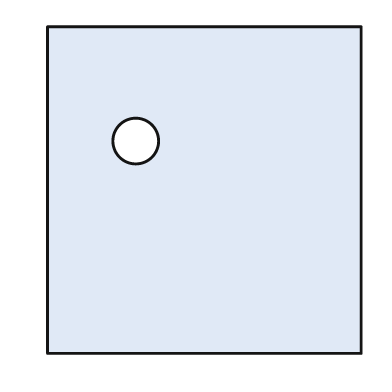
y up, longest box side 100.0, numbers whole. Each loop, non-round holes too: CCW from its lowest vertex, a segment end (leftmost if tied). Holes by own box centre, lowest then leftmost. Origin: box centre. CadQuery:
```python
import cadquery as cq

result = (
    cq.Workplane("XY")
    .moveTo(-48.0, -50.0)
    .lineTo(48.0, -50.0)
    .lineTo(48.0, 50.0)
    .lineTo(-48.0, 50.0)
    .close()
    .moveTo(-21.0, 15.0)
    .circle(7.0)
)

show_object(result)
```